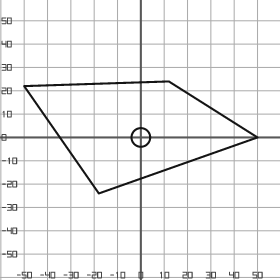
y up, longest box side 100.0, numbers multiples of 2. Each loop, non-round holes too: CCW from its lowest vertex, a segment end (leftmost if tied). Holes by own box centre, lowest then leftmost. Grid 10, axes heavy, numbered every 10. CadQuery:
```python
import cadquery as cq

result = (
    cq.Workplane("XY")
    .moveTo(-18.0, -24.0)
    .lineTo(50.0, 0.0)
    .lineTo(12.0, 24.0)
    .lineTo(-50.0, 22.0)
    .close()
    .moveTo(0.0, 0.0)
    .circle(4.0)
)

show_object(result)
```